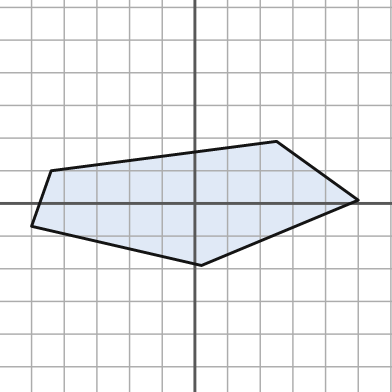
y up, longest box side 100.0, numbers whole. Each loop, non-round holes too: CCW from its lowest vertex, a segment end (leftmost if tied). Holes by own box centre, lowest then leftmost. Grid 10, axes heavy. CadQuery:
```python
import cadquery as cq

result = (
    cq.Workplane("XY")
    .moveTo(2.0, -19.0)
    .lineTo(50.0, 1.0)
    .lineTo(25.0, 19.0)
    .lineTo(-44.0, 10.0)
    .lineTo(-50.0, -7.0)
    .close()
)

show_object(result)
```